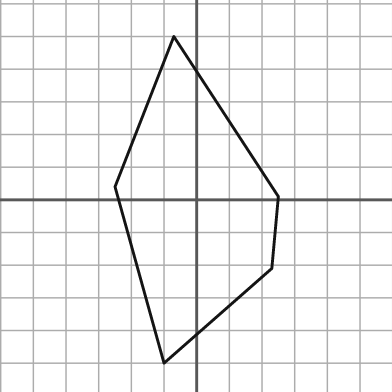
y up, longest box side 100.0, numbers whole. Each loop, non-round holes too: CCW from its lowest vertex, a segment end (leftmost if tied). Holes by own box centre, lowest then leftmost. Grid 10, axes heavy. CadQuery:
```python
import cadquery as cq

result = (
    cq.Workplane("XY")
    .moveTo(-10.0, -50.0)
    .lineTo(23.0, -21.0)
    .lineTo(25.0, 1.0)
    .lineTo(-7.0, 50.0)
    .lineTo(-25.0, 4.0)
    .close()
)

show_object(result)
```